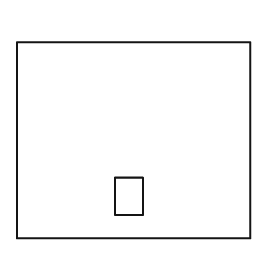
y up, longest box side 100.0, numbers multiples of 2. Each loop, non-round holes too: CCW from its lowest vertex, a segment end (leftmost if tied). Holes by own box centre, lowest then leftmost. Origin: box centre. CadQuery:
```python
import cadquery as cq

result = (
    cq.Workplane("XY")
    .moveTo(-50.0, -42.0)
    .lineTo(50.0, -42.0)
    .lineTo(50.0, 42.0)
    .lineTo(-50.0, 42.0)
    .close()
    .moveTo(-8.0, -32.0)
    .lineTo(4.0, -32.0)
    .lineTo(4.0, -16.0)
    .lineTo(-8.0, -16.0)
    .close()
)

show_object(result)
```